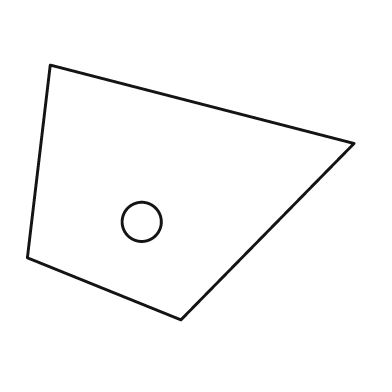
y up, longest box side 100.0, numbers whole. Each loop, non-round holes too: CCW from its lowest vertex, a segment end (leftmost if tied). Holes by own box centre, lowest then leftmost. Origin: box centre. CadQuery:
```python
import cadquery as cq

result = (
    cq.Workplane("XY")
    .moveTo(-3.0, -39.0)
    .lineTo(50.0, 15.0)
    .lineTo(-43.0, 39.0)
    .lineTo(-50.0, -20.0)
    .close()
    .moveTo(-15.0, -9.0)
    .circle(6.0)
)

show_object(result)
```